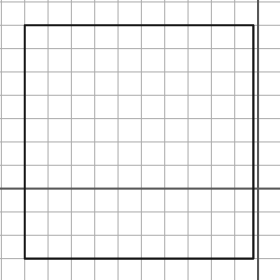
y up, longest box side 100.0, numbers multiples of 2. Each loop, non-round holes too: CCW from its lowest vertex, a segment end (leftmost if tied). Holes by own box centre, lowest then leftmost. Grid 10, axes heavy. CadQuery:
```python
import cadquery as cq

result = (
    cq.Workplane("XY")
    .moveTo(-100.0, -30.0)
    .lineTo(-2.0, -30.0)
    .lineTo(-2.0, 70.0)
    .lineTo(-100.0, 70.0)
    .close()
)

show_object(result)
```